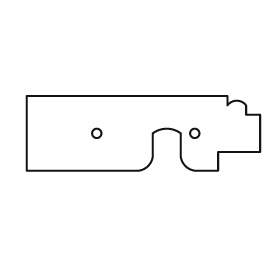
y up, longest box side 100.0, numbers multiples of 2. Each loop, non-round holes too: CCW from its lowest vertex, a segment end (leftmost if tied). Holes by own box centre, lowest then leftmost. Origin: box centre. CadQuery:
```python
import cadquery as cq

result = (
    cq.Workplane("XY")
    .moveTo(-50.0, -16.0)
    .lineTo(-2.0, -16.0)
    .threePointArc((2.0, -14.0), (4.0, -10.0))
    .lineTo(4.0, 0.0)
    .threePointArc((10.0, 2.0), (16.0, 0.0))
    .lineTo(16.0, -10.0)
    .threePointArc((18.0, -14.0), (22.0, -16.0))
    .lineTo(32.0, -16.0)
    .lineTo(32.0, -8.0)
    .lineTo(50.0, -8.0)
    .lineTo(50.0, 8.0)
    .lineTo(44.0, 8.0)
    .lineTo(44.0, 12.0)
    .threePointArc((40.0, 14.0), (36.0, 12.0))
    .lineTo(36.0, 16.0)
    .lineTo(-50.0, 16.0)
    .close()
    .moveTo(-20.0, 0.0)
    .circle(2.0)
    .moveTo(22.0, 0.0)
    .circle(2.0)
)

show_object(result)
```